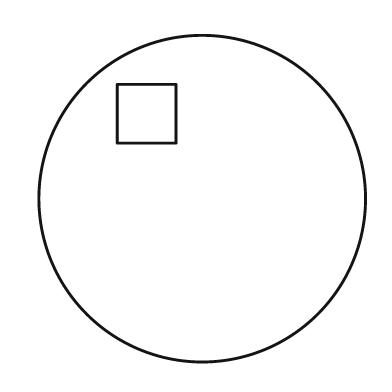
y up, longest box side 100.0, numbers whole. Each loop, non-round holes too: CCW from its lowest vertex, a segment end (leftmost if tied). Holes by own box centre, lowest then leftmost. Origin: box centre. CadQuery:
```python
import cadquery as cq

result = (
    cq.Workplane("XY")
    .moveTo(0.0, 0.0)
    .circle(50.0)
    .moveTo(-26.0, 17.0)
    .lineTo(-8.0, 17.0)
    .lineTo(-8.0, 35.0)
    .lineTo(-26.0, 35.0)
    .close()
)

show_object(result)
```